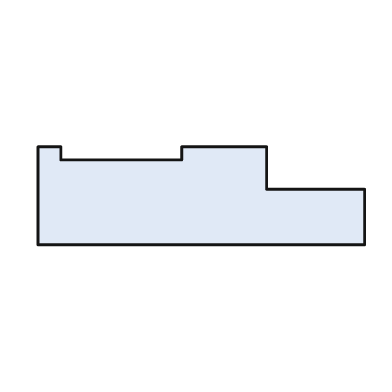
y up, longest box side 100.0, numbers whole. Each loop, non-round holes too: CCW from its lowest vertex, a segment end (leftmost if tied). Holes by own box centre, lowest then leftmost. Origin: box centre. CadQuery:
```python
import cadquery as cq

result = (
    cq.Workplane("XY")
    .moveTo(-50.0, -15.0)
    .lineTo(50.0, -15.0)
    .lineTo(50.0, 2.0)
    .lineTo(20.0, 2.0)
    .lineTo(20.0, 15.0)
    .lineTo(-6.0, 15.0)
    .lineTo(-6.0, 11.0)
    .lineTo(-43.0, 11.0)
    .lineTo(-43.0, 15.0)
    .lineTo(-50.0, 15.0)
    .close()
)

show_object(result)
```